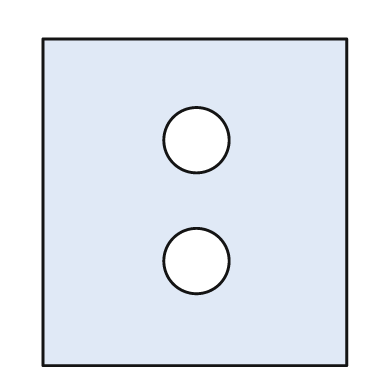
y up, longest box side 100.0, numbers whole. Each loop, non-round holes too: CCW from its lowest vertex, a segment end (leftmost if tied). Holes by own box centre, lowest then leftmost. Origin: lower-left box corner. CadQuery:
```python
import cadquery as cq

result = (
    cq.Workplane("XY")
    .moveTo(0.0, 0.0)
    .lineTo(93.0, 0.0)
    .lineTo(93.0, 100.0)
    .lineTo(0.0, 100.0)
    .close()
    .moveTo(47.0, 32.0)
    .circle(10.0)
    .moveTo(47.0, 69.0)
    .circle(10.0)
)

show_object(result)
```